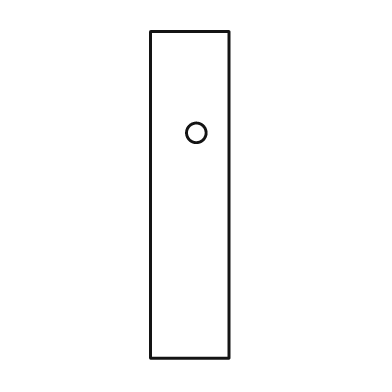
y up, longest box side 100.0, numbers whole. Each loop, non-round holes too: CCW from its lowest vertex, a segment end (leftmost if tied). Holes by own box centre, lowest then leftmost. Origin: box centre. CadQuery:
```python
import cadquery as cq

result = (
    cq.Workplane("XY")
    .moveTo(-12.0, -50.0)
    .lineTo(12.0, -50.0)
    .lineTo(12.0, 50.0)
    .lineTo(-12.0, 50.0)
    .close()
    .moveTo(2.0, 19.0)
    .circle(3.0)
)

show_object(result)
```